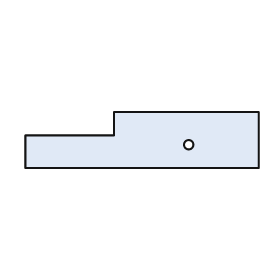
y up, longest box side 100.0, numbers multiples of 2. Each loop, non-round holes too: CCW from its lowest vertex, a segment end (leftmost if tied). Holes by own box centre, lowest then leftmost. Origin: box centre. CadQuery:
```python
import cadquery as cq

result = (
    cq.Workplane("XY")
    .moveTo(-50.0, -12.0)
    .lineTo(50.0, -12.0)
    .lineTo(50.0, 12.0)
    .lineTo(-12.0, 12.0)
    .lineTo(-12.0, 2.0)
    .lineTo(-50.0, 2.0)
    .close()
    .moveTo(20.0, -2.0)
    .circle(2.0)
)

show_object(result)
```